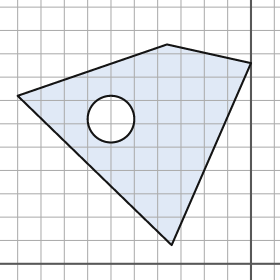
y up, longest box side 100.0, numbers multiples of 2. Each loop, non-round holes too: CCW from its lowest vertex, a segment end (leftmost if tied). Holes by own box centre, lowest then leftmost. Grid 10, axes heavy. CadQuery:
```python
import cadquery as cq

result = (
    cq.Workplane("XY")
    .moveTo(-34.0, 8.0)
    .lineTo(0.0, 86.0)
    .lineTo(-36.0, 94.0)
    .lineTo(-100.0, 72.0)
    .close()
    .moveTo(-60.0, 62.0)
    .circle(10.0)
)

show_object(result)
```